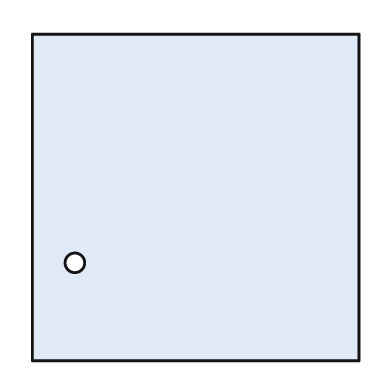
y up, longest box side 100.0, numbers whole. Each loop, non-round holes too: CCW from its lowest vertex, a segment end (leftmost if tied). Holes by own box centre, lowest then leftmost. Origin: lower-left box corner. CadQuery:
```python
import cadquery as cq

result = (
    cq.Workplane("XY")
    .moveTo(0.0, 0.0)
    .lineTo(100.0, 0.0)
    .lineTo(100.0, 100.0)
    .lineTo(0.0, 100.0)
    .close()
    .moveTo(13.0, 30.0)
    .circle(3.0)
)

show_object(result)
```